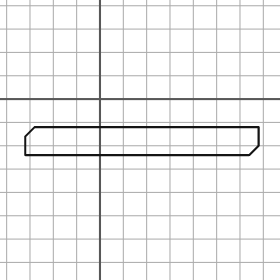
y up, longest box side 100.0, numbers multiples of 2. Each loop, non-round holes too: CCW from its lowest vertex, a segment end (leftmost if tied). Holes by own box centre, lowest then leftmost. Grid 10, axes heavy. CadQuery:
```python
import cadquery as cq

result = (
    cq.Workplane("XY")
    .moveTo(-32.0, -24.0)
    .lineTo(64.0, -24.0)
    .lineTo(68.0, -20.0)
    .lineTo(68.0, -12.0)
    .lineTo(-28.0, -12.0)
    .lineTo(-32.0, -16.0)
    .close()
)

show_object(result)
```